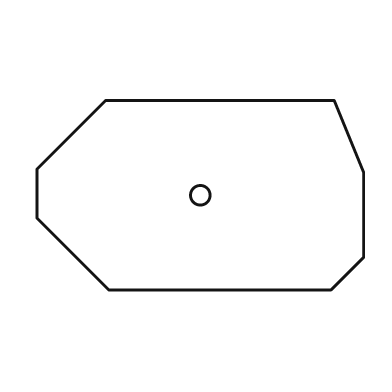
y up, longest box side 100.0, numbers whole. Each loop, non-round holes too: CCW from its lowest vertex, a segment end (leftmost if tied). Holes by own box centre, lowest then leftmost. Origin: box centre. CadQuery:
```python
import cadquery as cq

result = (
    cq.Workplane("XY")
    .moveTo(-28.0, -29.0)
    .lineTo(40.0, -29.0)
    .lineTo(50.0, -19.0)
    .lineTo(50.0, 7.0)
    .lineTo(41.0, 29.0)
    .lineTo(-29.0, 29.0)
    .lineTo(-50.0, 8.0)
    .lineTo(-50.0, -7.0)
    .close()
    .moveTo(0.0, 0.0)
    .circle(3.0)
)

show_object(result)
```